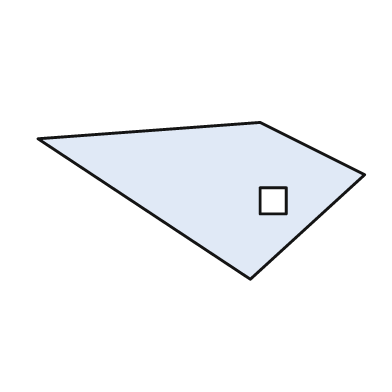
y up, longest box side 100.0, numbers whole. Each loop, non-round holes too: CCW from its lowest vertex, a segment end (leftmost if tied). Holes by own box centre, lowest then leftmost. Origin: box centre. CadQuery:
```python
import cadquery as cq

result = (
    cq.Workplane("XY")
    .moveTo(15.0, -24.0)
    .lineTo(50.0, 8.0)
    .lineTo(18.0, 24.0)
    .lineTo(-50.0, 19.0)
    .close()
    .moveTo(18.0, -4.0)
    .lineTo(26.0, -4.0)
    .lineTo(26.0, 4.0)
    .lineTo(18.0, 4.0)
    .close()
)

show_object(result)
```